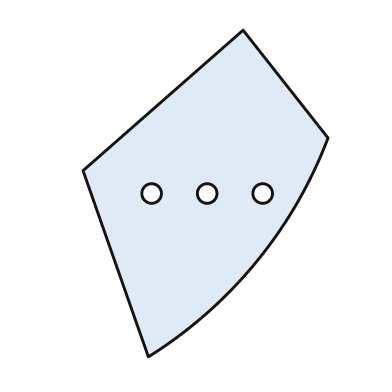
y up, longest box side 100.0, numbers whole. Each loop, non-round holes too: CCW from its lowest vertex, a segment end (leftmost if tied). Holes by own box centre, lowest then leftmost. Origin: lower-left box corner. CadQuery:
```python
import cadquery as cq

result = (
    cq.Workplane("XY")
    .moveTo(20.0, 0.0)
    .threePointArc((53.0, 29.0), (75.0, 67.0))
    .lineTo(49.0, 100.0)
    .lineTo(0.0, 57.0)
    .close()
    .moveTo(21.0, 50.0)
    .circle(3.0)
    .moveTo(38.0, 50.0)
    .circle(3.0)
    .moveTo(55.0, 50.0)
    .circle(3.0)
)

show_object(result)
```